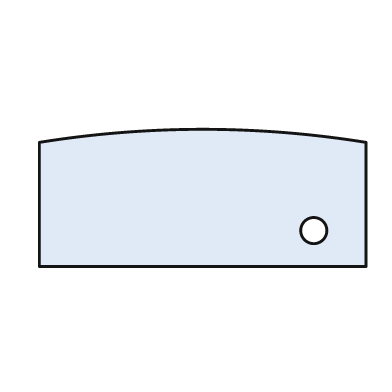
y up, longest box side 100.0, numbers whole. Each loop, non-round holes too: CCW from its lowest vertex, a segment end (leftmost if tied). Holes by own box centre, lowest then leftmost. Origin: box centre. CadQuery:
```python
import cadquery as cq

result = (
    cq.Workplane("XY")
    .moveTo(-50.0, -21.0)
    .lineTo(50.0, -21.0)
    .lineTo(50.0, 17.0)
    .threePointArc((0.0, 21.0), (-50.0, 17.0))
    .close()
    .moveTo(34.0, -10.0)
    .circle(4.0)
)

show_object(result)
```